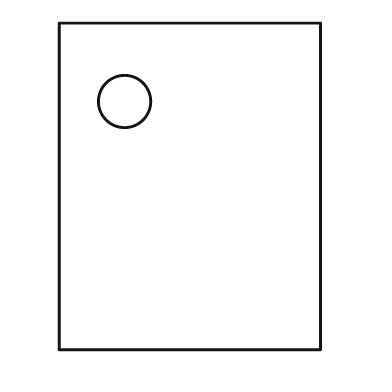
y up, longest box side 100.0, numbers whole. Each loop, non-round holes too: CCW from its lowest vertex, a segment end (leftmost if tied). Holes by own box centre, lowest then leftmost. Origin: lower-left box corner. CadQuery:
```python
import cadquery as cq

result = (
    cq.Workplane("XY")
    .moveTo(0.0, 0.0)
    .lineTo(80.0, 0.0)
    .lineTo(80.0, 100.0)
    .lineTo(0.0, 100.0)
    .close()
    .moveTo(20.0, 76.0)
    .circle(8.0)
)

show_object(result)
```